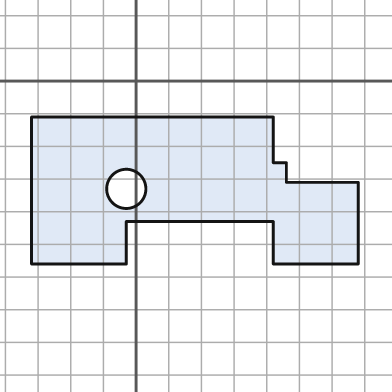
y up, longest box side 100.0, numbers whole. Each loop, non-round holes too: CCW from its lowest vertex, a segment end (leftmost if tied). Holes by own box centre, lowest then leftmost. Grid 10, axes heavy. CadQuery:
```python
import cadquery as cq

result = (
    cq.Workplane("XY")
    .moveTo(-32.0, -56.0)
    .lineTo(-3.0, -56.0)
    .lineTo(-3.0, -43.0)
    .lineTo(42.0, -43.0)
    .lineTo(42.0, -56.0)
    .lineTo(68.0, -56.0)
    .lineTo(68.0, -31.0)
    .lineTo(46.0, -31.0)
    .lineTo(46.0, -25.0)
    .lineTo(42.0, -25.0)
    .lineTo(42.0, -11.0)
    .lineTo(-32.0, -11.0)
    .close()
    .moveTo(-3.0, -33.0)
    .circle(6.0)
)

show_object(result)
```